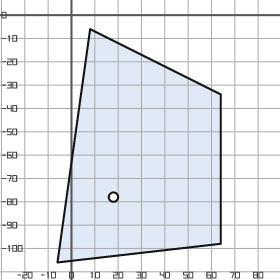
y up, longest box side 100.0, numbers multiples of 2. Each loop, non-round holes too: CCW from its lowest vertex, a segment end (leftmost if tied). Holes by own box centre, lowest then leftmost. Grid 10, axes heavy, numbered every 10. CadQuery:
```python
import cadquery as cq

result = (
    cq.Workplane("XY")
    .moveTo(-6.0, -106.0)
    .lineTo(64.0, -98.0)
    .lineTo(64.0, -34.0)
    .lineTo(8.0, -6.0)
    .close()
    .moveTo(18.0, -78.0)
    .circle(2.0)
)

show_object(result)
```